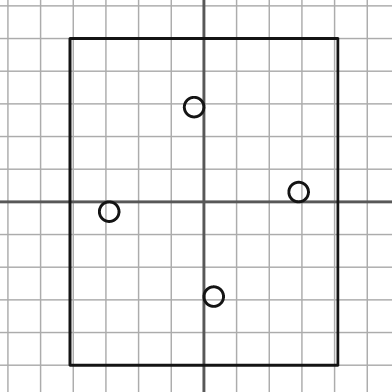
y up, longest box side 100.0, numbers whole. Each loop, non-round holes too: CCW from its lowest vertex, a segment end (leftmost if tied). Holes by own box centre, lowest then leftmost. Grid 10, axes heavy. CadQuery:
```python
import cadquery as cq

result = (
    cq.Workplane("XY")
    .moveTo(-41.0, -50.0)
    .lineTo(41.0, -50.0)
    .lineTo(41.0, 50.0)
    .lineTo(-41.0, 50.0)
    .close()
    .moveTo(3.0, -29.0)
    .circle(3.0)
    .moveTo(-29.0, -3.0)
    .circle(3.0)
    .moveTo(29.0, 3.0)
    .circle(3.0)
    .moveTo(-3.0, 29.0)
    .circle(3.0)
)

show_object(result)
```